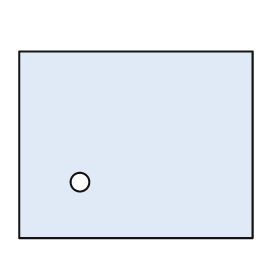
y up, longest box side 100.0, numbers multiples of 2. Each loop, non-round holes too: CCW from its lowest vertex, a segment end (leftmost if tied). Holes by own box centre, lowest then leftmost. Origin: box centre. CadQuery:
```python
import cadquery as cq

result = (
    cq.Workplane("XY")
    .moveTo(-50.0, -40.0)
    .lineTo(50.0, -40.0)
    .lineTo(50.0, 40.0)
    .lineTo(-50.0, 40.0)
    .close()
    .moveTo(-24.0, -16.0)
    .circle(4.0)
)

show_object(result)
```